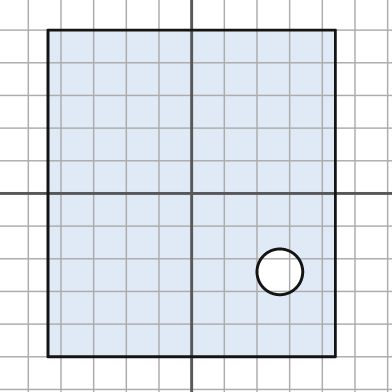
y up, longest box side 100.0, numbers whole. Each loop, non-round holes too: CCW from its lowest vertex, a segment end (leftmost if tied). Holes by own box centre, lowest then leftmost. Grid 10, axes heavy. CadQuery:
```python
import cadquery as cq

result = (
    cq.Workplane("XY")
    .moveTo(-44.0, -50.0)
    .lineTo(44.0, -50.0)
    .lineTo(44.0, 50.0)
    .lineTo(-44.0, 50.0)
    .close()
    .moveTo(27.0, -24.0)
    .circle(7.0)
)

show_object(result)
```